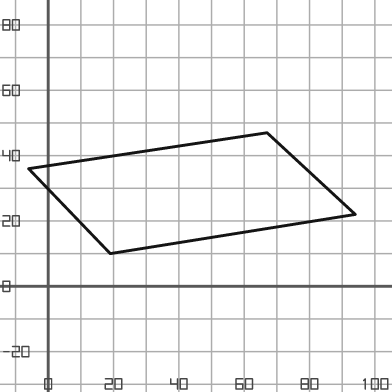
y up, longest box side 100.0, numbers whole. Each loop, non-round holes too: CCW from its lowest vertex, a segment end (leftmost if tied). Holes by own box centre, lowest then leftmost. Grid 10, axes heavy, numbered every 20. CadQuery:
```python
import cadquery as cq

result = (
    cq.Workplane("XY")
    .moveTo(19.0, 10.0)
    .lineTo(94.0, 22.0)
    .lineTo(67.0, 47.0)
    .lineTo(-6.0, 36.0)
    .close()
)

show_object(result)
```